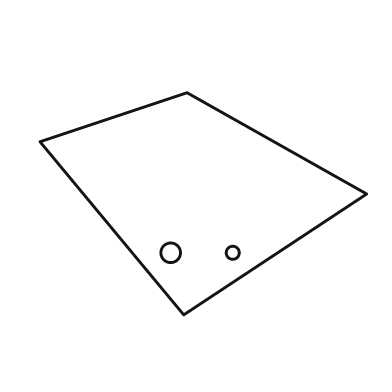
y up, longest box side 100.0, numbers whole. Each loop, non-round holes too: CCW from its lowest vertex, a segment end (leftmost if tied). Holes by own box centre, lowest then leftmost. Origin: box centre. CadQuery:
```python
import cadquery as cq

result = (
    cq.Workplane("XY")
    .moveTo(-6.0, -34.0)
    .lineTo(50.0, 3.0)
    .lineTo(-5.0, 34.0)
    .lineTo(-50.0, 19.0)
    .close()
    .moveTo(-10.0, -15.0)
    .circle(3.0)
    .moveTo(9.0, -15.0)
    .circle(2.0)
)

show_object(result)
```